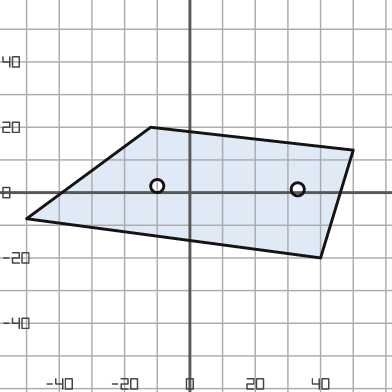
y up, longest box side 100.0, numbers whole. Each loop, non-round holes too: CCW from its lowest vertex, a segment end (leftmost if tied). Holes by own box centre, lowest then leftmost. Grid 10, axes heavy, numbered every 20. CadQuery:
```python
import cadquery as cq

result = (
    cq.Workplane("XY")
    .moveTo(40.0, -20.0)
    .lineTo(50.0, 13.0)
    .lineTo(-12.0, 20.0)
    .lineTo(-50.0, -8.0)
    .close()
    .moveTo(33.0, 1.0)
    .circle(2.0)
    .moveTo(-10.0, 2.0)
    .circle(2.0)
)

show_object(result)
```